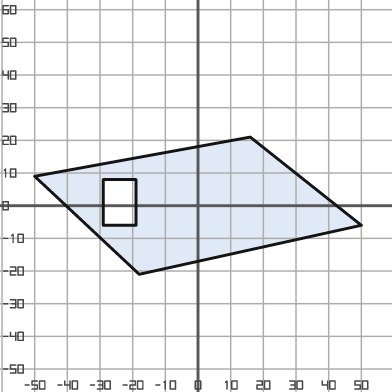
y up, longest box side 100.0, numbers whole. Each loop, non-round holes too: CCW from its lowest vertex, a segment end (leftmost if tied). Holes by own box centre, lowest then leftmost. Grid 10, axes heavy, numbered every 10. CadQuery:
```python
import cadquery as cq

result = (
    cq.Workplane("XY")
    .moveTo(-18.0, -21.0)
    .lineTo(50.0, -6.0)
    .lineTo(16.0, 21.0)
    .lineTo(-50.0, 9.0)
    .close()
    .moveTo(-29.0, -6.0)
    .lineTo(-19.0, -6.0)
    .lineTo(-19.0, 8.0)
    .lineTo(-29.0, 8.0)
    .close()
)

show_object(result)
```